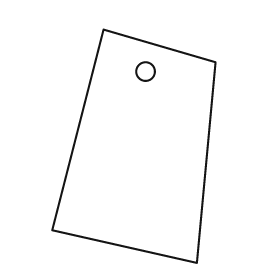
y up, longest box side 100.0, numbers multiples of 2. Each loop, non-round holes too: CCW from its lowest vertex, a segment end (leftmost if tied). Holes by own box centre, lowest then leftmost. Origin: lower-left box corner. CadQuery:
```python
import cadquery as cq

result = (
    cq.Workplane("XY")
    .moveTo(62.0, 0.0)
    .lineTo(70.0, 86.0)
    .lineTo(22.0, 100.0)
    .lineTo(0.0, 14.0)
    .close()
    .moveTo(40.0, 82.0)
    .circle(4.0)
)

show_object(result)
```